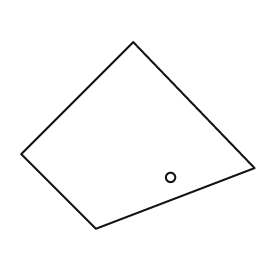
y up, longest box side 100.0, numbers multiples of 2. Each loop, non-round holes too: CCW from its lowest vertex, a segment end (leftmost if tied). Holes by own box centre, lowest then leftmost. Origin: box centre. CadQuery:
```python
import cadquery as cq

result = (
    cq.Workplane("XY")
    .moveTo(-18.0, -40.0)
    .lineTo(50.0, -14.0)
    .lineTo(-2.0, 40.0)
    .lineTo(-50.0, -8.0)
    .close()
    .moveTo(14.0, -18.0)
    .circle(2.0)
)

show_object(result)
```